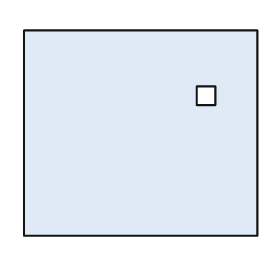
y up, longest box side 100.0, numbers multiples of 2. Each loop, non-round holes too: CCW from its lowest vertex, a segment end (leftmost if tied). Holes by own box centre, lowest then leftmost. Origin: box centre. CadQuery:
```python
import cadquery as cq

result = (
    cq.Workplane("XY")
    .moveTo(-50.0, -44.0)
    .lineTo(50.0, -44.0)
    .lineTo(50.0, 44.0)
    .lineTo(-50.0, 44.0)
    .close()
    .moveTo(24.0, 12.0)
    .lineTo(32.0, 12.0)
    .lineTo(32.0, 20.0)
    .lineTo(24.0, 20.0)
    .close()
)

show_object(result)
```